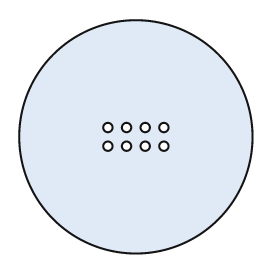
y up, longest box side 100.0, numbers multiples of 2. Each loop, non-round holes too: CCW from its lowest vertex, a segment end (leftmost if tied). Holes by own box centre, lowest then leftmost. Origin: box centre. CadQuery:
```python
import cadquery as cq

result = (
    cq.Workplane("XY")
    .moveTo(0.0, 0.0)
    .circle(50.0)
    .moveTo(-12.0, -4.0)
    .circle(2.0)
    .moveTo(-4.0, -4.0)
    .circle(2.0)
    .moveTo(4.0, -4.0)
    .circle(2.0)
    .moveTo(12.0, -4.0)
    .circle(2.0)
    .moveTo(-12.0, 4.0)
    .circle(2.0)
    .moveTo(-4.0, 4.0)
    .circle(2.0)
    .moveTo(4.0, 4.0)
    .circle(2.0)
    .moveTo(12.0, 4.0)
    .circle(2.0)
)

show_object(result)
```